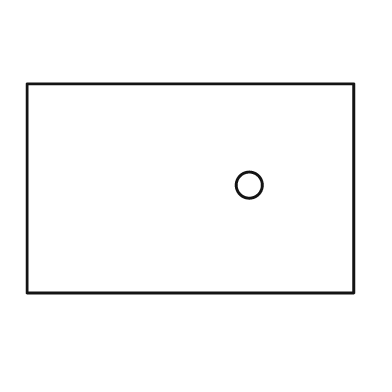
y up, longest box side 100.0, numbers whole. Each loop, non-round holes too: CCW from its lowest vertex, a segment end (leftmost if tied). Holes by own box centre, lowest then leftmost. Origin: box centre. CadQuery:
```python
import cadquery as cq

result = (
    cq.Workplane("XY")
    .moveTo(-50.0, -32.0)
    .lineTo(50.0, -32.0)
    .lineTo(50.0, 32.0)
    .lineTo(-50.0, 32.0)
    .close()
    .moveTo(18.0, 1.0)
    .circle(4.0)
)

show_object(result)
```